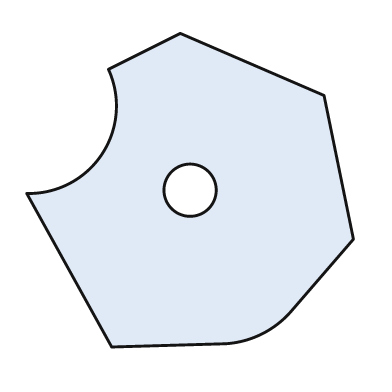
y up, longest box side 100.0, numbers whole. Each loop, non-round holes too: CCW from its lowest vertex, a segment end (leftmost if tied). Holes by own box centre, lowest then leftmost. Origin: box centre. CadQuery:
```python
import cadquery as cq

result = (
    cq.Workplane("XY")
    .moveTo(-24.0, -48.0)
    .lineTo(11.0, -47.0)
    .threePointArc((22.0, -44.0), (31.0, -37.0))
    .lineTo(50.0, -15.0)
    .lineTo(41.0, 29.0)
    .lineTo(-3.0, 48.0)
    .lineTo(-25.0, 37.0)
    .threePointArc((-27.0, 11.0), (-50.0, -1.0))
    .close()
    .moveTo(0.0, 0.0)
    .circle(8.0)
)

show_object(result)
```